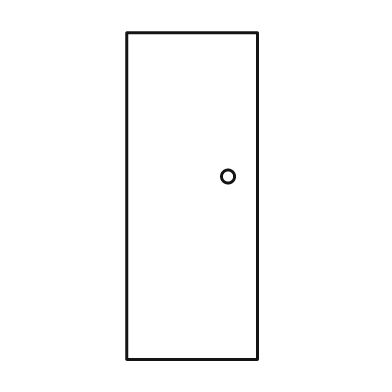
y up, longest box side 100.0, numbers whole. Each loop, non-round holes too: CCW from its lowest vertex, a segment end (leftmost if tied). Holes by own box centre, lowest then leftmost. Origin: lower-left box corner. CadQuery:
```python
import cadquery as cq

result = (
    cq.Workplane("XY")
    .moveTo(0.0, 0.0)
    .lineTo(40.0, 0.0)
    .lineTo(40.0, 100.0)
    .lineTo(0.0, 100.0)
    .close()
    .moveTo(31.0, 56.0)
    .circle(2.0)
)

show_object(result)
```